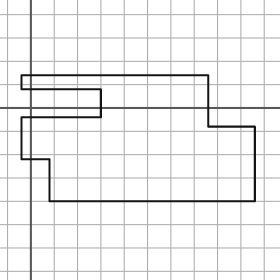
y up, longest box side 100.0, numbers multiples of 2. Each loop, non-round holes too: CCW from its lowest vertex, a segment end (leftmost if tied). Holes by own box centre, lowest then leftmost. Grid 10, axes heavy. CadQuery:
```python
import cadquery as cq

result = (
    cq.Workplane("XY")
    .moveTo(8.0, -40.0)
    .lineTo(96.0, -40.0)
    .lineTo(96.0, -8.0)
    .lineTo(76.0, -8.0)
    .lineTo(76.0, 14.0)
    .lineTo(-4.0, 14.0)
    .lineTo(-4.0, 8.0)
    .lineTo(30.0, 8.0)
    .lineTo(30.0, -4.0)
    .lineTo(-4.0, -4.0)
    .lineTo(-4.0, -22.0)
    .lineTo(8.0, -22.0)
    .close()
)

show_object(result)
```